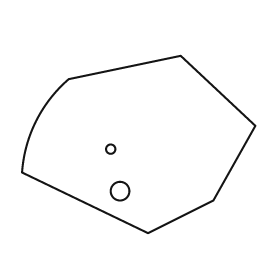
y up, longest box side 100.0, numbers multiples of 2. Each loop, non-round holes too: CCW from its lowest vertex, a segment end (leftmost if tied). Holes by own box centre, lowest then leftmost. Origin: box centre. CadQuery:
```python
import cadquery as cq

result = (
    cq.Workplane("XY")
    .moveTo(4.0, -38.0)
    .lineTo(32.0, -24.0)
    .lineTo(50.0, 8.0)
    .lineTo(18.0, 38.0)
    .lineTo(-30.0, 28.0)
    .threePointArc((-44.0, 10.0), (-50.0, -12.0))
    .close()
    .moveTo(-8.0, -20.0)
    .circle(4.0)
    .moveTo(-12.0, -2.0)
    .circle(2.0)
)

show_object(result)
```